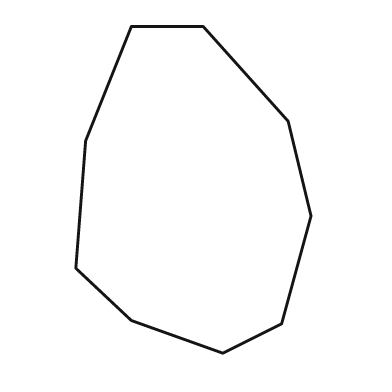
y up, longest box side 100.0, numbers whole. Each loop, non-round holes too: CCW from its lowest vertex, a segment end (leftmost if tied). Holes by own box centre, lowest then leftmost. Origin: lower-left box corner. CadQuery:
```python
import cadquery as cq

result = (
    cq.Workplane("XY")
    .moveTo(45.0, 0.0)
    .lineTo(63.0, 9.0)
    .lineTo(72.0, 42.0)
    .lineTo(65.0, 71.0)
    .lineTo(39.0, 100.0)
    .lineTo(17.0, 100.0)
    .lineTo(3.0, 65.0)
    .lineTo(0.0, 26.0)
    .lineTo(17.0, 10.0)
    .close()
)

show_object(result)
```